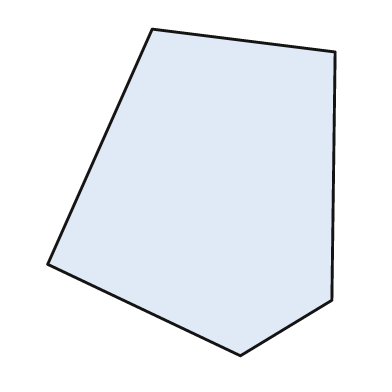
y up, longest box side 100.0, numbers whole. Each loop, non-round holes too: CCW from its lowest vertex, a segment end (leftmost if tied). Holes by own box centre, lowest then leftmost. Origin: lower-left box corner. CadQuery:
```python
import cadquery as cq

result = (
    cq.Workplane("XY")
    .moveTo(59.0, 0.0)
    .lineTo(87.0, 17.0)
    .lineTo(88.0, 93.0)
    .lineTo(32.0, 100.0)
    .lineTo(0.0, 28.0)
    .close()
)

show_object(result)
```